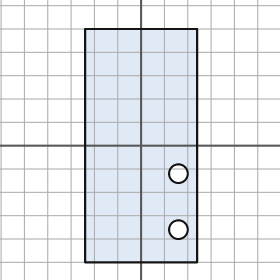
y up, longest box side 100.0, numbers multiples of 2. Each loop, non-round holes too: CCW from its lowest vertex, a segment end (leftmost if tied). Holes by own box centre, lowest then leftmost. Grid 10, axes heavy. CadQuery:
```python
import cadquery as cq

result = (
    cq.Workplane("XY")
    .moveTo(-24.0, -50.0)
    .lineTo(24.0, -50.0)
    .lineTo(24.0, 50.0)
    .lineTo(-24.0, 50.0)
    .close()
    .moveTo(16.0, -36.0)
    .circle(4.0)
    .moveTo(16.0, -12.0)
    .circle(4.0)
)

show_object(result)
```